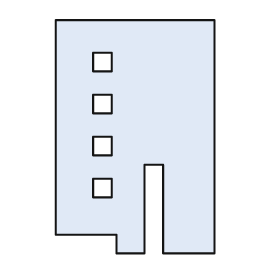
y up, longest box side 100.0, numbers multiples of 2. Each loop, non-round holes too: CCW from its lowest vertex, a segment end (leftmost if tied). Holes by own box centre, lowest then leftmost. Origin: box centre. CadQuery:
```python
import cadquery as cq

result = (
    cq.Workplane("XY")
    .moveTo(-8.0, -50.0)
    .lineTo(4.0, -50.0)
    .lineTo(4.0, -12.0)
    .lineTo(12.0, -12.0)
    .lineTo(12.0, -50.0)
    .lineTo(34.0, -50.0)
    .lineTo(34.0, 50.0)
    .lineTo(-34.0, 50.0)
    .lineTo(-34.0, -42.0)
    .lineTo(-8.0, -42.0)
    .close()
    .moveTo(-18.0, -26.0)
    .lineTo(-10.0, -26.0)
    .lineTo(-10.0, -18.0)
    .lineTo(-18.0, -18.0)
    .close()
    .moveTo(-18.0, -8.0)
    .lineTo(-10.0, -8.0)
    .lineTo(-10.0, 0.0)
    .lineTo(-18.0, 0.0)
    .close()
    .moveTo(-18.0, 10.0)
    .lineTo(-10.0, 10.0)
    .lineTo(-10.0, 18.0)
    .lineTo(-18.0, 18.0)
    .close()
    .moveTo(-18.0, 28.0)
    .lineTo(-10.0, 28.0)
    .lineTo(-10.0, 36.0)
    .lineTo(-18.0, 36.0)
    .close()
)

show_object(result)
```